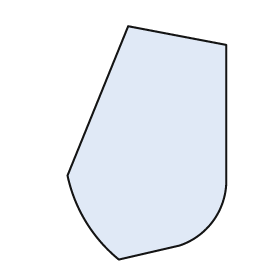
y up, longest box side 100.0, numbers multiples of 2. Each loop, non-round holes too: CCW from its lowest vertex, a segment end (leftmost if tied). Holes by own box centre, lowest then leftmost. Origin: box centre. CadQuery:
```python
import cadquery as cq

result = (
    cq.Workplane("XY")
    .moveTo(-12.0, -50.0)
    .lineTo(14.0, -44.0)
    .threePointArc((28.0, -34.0), (34.0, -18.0))
    .lineTo(34.0, 42.0)
    .lineTo(-8.0, 50.0)
    .lineTo(-34.0, -14.0)
    .threePointArc((-26.0, -34.0), (-12.0, -50.0))
    .close()
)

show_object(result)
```